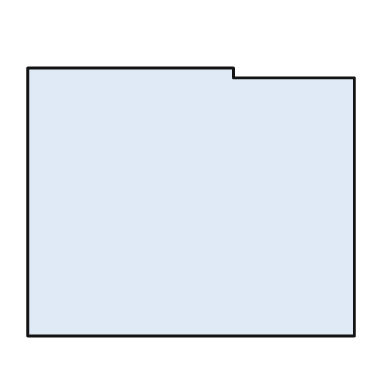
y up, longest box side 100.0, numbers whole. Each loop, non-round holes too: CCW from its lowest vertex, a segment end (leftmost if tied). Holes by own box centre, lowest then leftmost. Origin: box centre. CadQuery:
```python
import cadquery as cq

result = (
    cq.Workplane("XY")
    .moveTo(-50.0, -41.0)
    .lineTo(50.0, -41.0)
    .lineTo(50.0, 38.0)
    .lineTo(13.0, 38.0)
    .lineTo(13.0, 41.0)
    .lineTo(-50.0, 41.0)
    .close()
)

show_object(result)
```